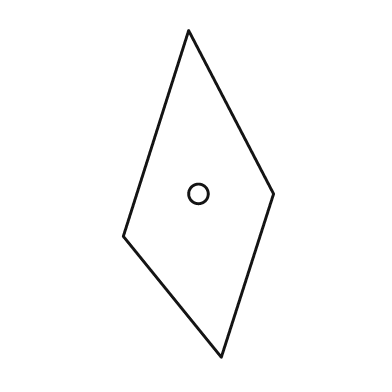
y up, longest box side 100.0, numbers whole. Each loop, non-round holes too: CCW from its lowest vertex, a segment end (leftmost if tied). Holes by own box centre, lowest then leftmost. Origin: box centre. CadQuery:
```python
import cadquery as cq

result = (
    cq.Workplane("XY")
    .moveTo(7.0, -50.0)
    .lineTo(23.0, 0.0)
    .lineTo(-3.0, 50.0)
    .lineTo(-23.0, -13.0)
    .close()
    .moveTo(0.0, 0.0)
    .circle(3.0)
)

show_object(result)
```